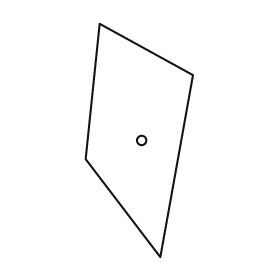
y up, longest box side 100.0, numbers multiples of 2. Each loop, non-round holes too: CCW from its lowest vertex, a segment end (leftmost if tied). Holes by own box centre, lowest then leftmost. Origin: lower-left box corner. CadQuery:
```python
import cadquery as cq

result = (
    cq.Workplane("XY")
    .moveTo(32.0, 0.0)
    .lineTo(46.0, 78.0)
    .lineTo(6.0, 100.0)
    .lineTo(0.0, 42.0)
    .close()
    .moveTo(24.0, 50.0)
    .circle(2.0)
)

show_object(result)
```